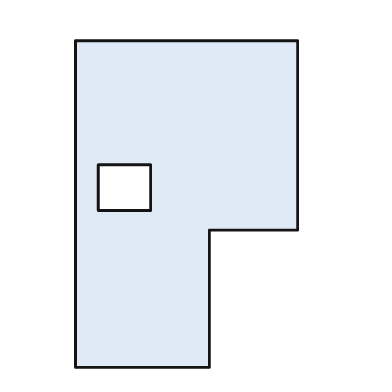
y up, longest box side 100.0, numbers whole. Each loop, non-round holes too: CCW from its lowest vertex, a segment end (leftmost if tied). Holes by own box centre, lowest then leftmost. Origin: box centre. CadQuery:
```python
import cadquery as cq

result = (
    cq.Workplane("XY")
    .moveTo(-34.0, -50.0)
    .lineTo(7.0, -50.0)
    .lineTo(7.0, -8.0)
    .lineTo(34.0, -8.0)
    .lineTo(34.0, 50.0)
    .lineTo(-34.0, 50.0)
    .close()
    .moveTo(-27.0, -2.0)
    .lineTo(-11.0, -2.0)
    .lineTo(-11.0, 12.0)
    .lineTo(-27.0, 12.0)
    .close()
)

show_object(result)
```